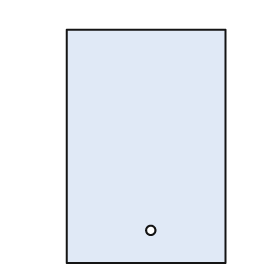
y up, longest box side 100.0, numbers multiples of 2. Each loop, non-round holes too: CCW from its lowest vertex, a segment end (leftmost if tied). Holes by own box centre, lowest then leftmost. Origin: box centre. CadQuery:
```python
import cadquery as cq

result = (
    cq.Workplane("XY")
    .moveTo(-34.0, -50.0)
    .lineTo(34.0, -50.0)
    .lineTo(34.0, 50.0)
    .lineTo(-34.0, 50.0)
    .close()
    .moveTo(2.0, -36.0)
    .circle(2.0)
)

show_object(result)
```